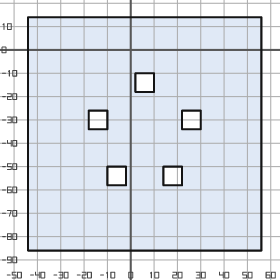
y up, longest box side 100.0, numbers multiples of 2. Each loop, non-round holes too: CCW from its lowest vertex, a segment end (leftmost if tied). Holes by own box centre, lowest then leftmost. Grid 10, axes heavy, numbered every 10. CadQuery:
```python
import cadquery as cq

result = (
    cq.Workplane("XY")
    .moveTo(-44.0, -86.0)
    .lineTo(56.0, -86.0)
    .lineTo(56.0, 14.0)
    .lineTo(-44.0, 14.0)
    .close()
    .moveTo(-10.0, -58.0)
    .lineTo(-2.0, -58.0)
    .lineTo(-2.0, -50.0)
    .lineTo(-10.0, -50.0)
    .close()
    .moveTo(14.0, -58.0)
    .lineTo(22.0, -58.0)
    .lineTo(22.0, -50.0)
    .lineTo(14.0, -50.0)
    .close()
    .moveTo(-18.0, -34.0)
    .lineTo(-10.0, -34.0)
    .lineTo(-10.0, -26.0)
    .lineTo(-18.0, -26.0)
    .close()
    .moveTo(22.0, -34.0)
    .lineTo(30.0, -34.0)
    .lineTo(30.0, -26.0)
    .lineTo(22.0, -26.0)
    .close()
    .moveTo(2.0, -18.0)
    .lineTo(10.0, -18.0)
    .lineTo(10.0, -10.0)
    .lineTo(2.0, -10.0)
    .close()
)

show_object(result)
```